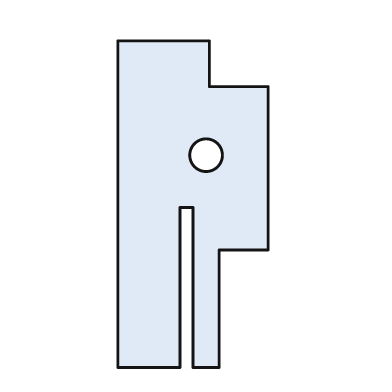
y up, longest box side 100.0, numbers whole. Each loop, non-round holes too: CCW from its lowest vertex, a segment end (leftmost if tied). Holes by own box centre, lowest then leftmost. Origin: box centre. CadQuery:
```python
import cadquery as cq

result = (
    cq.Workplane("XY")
    .moveTo(-23.0, -50.0)
    .lineTo(-4.0, -50.0)
    .lineTo(-4.0, -1.0)
    .lineTo(0.0, -1.0)
    .lineTo(0.0, -50.0)
    .lineTo(8.0, -50.0)
    .lineTo(8.0, -14.0)
    .lineTo(23.0, -14.0)
    .lineTo(23.0, 36.0)
    .lineTo(5.0, 36.0)
    .lineTo(5.0, 50.0)
    .lineTo(-23.0, 50.0)
    .close()
    .moveTo(4.0, 15.0)
    .circle(5.0)
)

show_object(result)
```